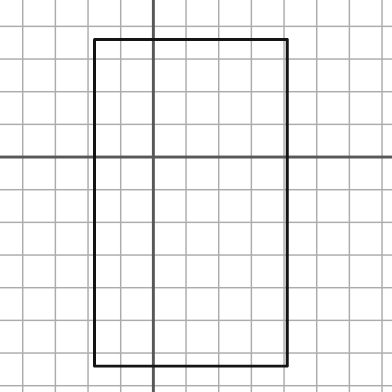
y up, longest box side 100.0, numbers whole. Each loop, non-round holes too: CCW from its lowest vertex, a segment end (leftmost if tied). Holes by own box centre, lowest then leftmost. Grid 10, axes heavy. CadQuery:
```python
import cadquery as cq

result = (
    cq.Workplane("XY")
    .moveTo(-18.0, -64.0)
    .lineTo(41.0, -64.0)
    .lineTo(41.0, 36.0)
    .lineTo(-18.0, 36.0)
    .close()
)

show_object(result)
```